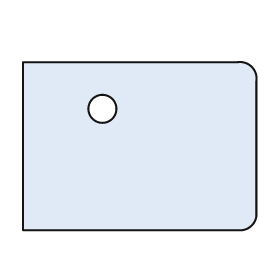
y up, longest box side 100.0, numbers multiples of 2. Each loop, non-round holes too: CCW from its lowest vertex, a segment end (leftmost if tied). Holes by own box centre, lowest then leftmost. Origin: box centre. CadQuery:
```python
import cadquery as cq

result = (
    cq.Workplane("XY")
    .moveTo(-50.0, -36.0)
    .lineTo(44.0, -36.0)
    .threePointArc((48.0, -34.0), (50.0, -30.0))
    .lineTo(50.0, 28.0)
    .threePointArc((48.0, 34.0), (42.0, 36.0))
    .lineTo(-50.0, 36.0)
    .close()
    .moveTo(-16.0, 16.0)
    .circle(6.0)
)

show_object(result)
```